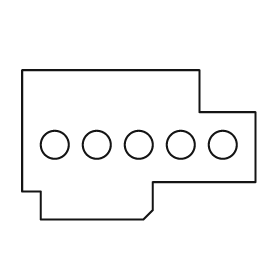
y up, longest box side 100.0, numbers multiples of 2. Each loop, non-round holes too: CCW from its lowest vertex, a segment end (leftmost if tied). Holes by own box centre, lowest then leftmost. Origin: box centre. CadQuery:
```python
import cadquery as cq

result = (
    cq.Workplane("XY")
    .moveTo(-42.0, -32.0)
    .lineTo(2.0, -32.0)
    .lineTo(6.0, -28.0)
    .lineTo(6.0, -16.0)
    .lineTo(50.0, -16.0)
    .lineTo(50.0, 14.0)
    .lineTo(26.0, 14.0)
    .lineTo(26.0, 32.0)
    .lineTo(-50.0, 32.0)
    .lineTo(-50.0, -20.0)
    .lineTo(-42.0, -20.0)
    .close()
    .moveTo(-36.0, 0.0)
    .circle(6.0)
    .moveTo(-18.0, 0.0)
    .circle(6.0)
    .moveTo(0.0, 0.0)
    .circle(6.0)
    .moveTo(18.0, 0.0)
    .circle(6.0)
    .moveTo(36.0, 0.0)
    .circle(6.0)
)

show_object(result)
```